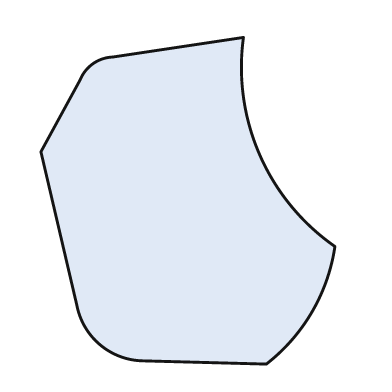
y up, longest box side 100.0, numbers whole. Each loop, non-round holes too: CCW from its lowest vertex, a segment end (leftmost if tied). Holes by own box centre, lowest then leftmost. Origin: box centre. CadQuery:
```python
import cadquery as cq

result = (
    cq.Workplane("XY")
    .moveTo(24.0, -50.0)
    .threePointArc((38.0, -34.0), (45.0, -14.0))
    .threePointArc((22.0, 14.0), (17.0, 50.0))
    .lineTo(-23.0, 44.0)
    .threePointArc((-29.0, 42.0), (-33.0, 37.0))
    .lineTo(-45.0, 15.0)
    .lineTo(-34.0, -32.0)
    .threePointArc((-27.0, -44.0), (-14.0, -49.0))
    .close()
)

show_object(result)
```